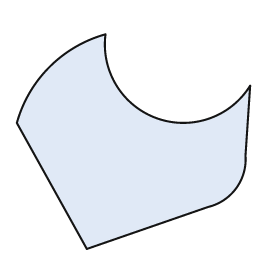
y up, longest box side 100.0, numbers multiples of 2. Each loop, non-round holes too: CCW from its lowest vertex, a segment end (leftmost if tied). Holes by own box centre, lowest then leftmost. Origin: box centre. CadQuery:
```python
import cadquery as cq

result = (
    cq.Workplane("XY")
    .moveTo(-20.0, -46.0)
    .lineTo(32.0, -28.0)
    .threePointArc((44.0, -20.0), (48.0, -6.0))
    .lineTo(50.0, 24.0)
    .threePointArc((10.0, 10.0), (-12.0, 46.0))
    .threePointArc((-36.0, 32.0), (-50.0, 8.0))
    .close()
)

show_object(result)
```